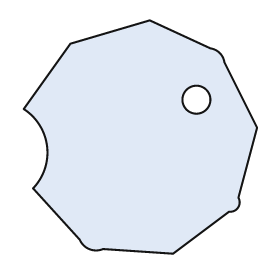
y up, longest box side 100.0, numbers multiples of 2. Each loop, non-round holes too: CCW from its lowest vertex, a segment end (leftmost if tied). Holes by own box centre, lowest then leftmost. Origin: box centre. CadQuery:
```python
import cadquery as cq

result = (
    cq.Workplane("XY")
    .moveTo(14.0, -50.0)
    .lineTo(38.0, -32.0)
    .threePointArc((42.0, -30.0), (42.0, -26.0))
    .lineTo(50.0, 4.0)
    .lineTo(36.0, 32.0)
    .threePointArc((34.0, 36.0), (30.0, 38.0))
    .lineTo(4.0, 50.0)
    .lineTo(-30.0, 40.0)
    .lineTo(-50.0, 12.0)
    .threePointArc((-40.0, -4.0), (-46.0, -22.0))
    .lineTo(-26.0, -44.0)
    .threePointArc((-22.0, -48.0), (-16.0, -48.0))
    .close()
    .moveTo(24.0, 16.0)
    .circle(6.0)
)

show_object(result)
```